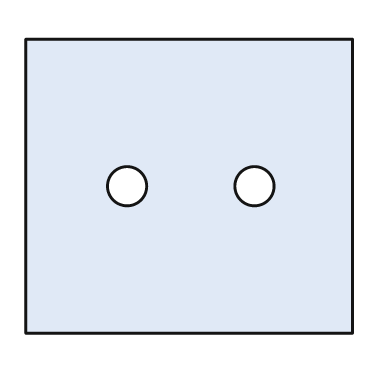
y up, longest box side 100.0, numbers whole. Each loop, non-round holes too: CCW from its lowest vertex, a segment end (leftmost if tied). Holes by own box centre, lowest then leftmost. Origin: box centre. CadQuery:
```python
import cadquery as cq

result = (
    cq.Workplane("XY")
    .moveTo(-50.0, -45.0)
    .lineTo(50.0, -45.0)
    .lineTo(50.0, 45.0)
    .lineTo(-50.0, 45.0)
    .close()
    .moveTo(-19.0, 0.0)
    .circle(6.0)
    .moveTo(20.0, 0.0)
    .circle(6.0)
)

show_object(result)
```